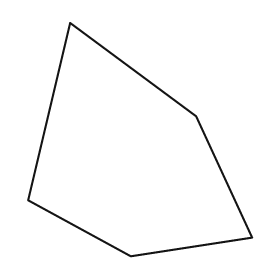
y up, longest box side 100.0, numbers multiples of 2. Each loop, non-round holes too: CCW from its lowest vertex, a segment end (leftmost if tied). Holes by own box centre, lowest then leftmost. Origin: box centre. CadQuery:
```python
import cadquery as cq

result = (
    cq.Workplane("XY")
    .moveTo(-4.0, -50.0)
    .lineTo(48.0, -42.0)
    .lineTo(24.0, 10.0)
    .lineTo(-30.0, 50.0)
    .lineTo(-48.0, -26.0)
    .close()
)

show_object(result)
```